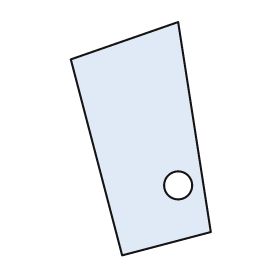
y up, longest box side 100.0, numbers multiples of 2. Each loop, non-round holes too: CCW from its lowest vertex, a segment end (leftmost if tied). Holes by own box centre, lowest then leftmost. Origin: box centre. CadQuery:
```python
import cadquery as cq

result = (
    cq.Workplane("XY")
    .moveTo(-8.0, -50.0)
    .lineTo(30.0, -40.0)
    .lineTo(16.0, 50.0)
    .lineTo(-30.0, 34.0)
    .close()
    .moveTo(16.0, -20.0)
    .circle(6.0)
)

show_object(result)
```